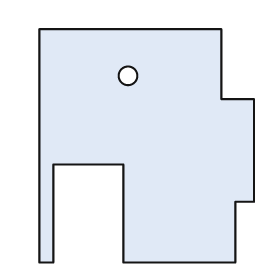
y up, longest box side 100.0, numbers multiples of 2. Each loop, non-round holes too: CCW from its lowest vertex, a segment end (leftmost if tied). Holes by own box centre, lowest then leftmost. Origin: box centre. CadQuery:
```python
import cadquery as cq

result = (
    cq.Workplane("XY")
    .moveTo(-46.0, -50.0)
    .lineTo(-40.0, -50.0)
    .lineTo(-40.0, -8.0)
    .lineTo(-10.0, -8.0)
    .lineTo(-10.0, -50.0)
    .lineTo(38.0, -50.0)
    .lineTo(38.0, -24.0)
    .lineTo(46.0, -24.0)
    .lineTo(46.0, 20.0)
    .lineTo(32.0, 20.0)
    .lineTo(32.0, 50.0)
    .lineTo(-46.0, 50.0)
    .close()
    .moveTo(-8.0, 30.0)
    .circle(4.0)
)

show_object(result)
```